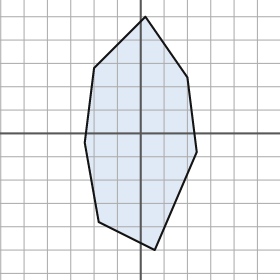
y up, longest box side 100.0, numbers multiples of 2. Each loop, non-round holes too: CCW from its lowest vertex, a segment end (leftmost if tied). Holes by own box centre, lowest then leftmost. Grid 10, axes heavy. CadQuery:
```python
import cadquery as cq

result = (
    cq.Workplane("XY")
    .moveTo(6.0, -50.0)
    .lineTo(24.0, -8.0)
    .lineTo(20.0, 24.0)
    .lineTo(2.0, 50.0)
    .lineTo(-20.0, 28.0)
    .lineTo(-24.0, -4.0)
    .lineTo(-18.0, -38.0)
    .close()
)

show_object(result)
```